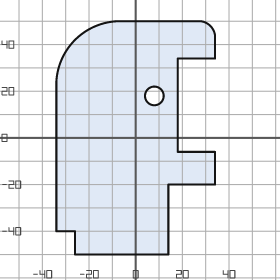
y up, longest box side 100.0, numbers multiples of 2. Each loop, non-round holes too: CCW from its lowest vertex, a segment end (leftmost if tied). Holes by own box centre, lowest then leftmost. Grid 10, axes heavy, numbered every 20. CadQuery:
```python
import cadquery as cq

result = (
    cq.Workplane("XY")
    .moveTo(-26.0, -50.0)
    .lineTo(14.0, -50.0)
    .lineTo(14.0, -20.0)
    .lineTo(34.0, -20.0)
    .lineTo(34.0, -6.0)
    .lineTo(18.0, -6.0)
    .lineTo(18.0, 34.0)
    .lineTo(34.0, 34.0)
    .lineTo(34.0, 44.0)
    .threePointArc((32.0, 48.0), (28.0, 50.0))
    .lineTo(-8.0, 50.0)
    .threePointArc((-26.0, 42.0), (-34.0, 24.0))
    .lineTo(-34.0, -40.0)
    .lineTo(-26.0, -40.0)
    .close()
    .moveTo(8.0, 18.0)
    .circle(4.0)
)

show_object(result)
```